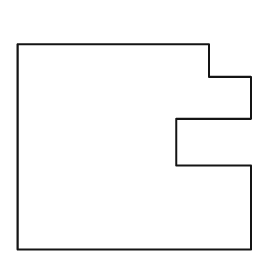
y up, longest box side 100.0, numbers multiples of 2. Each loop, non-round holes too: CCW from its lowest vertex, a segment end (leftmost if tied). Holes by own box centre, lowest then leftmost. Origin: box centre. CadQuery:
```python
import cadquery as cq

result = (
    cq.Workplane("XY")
    .moveTo(-50.0, -44.0)
    .lineTo(50.0, -44.0)
    .lineTo(50.0, -8.0)
    .lineTo(18.0, -8.0)
    .lineTo(18.0, 12.0)
    .lineTo(50.0, 12.0)
    .lineTo(50.0, 30.0)
    .lineTo(32.0, 30.0)
    .lineTo(32.0, 44.0)
    .lineTo(-50.0, 44.0)
    .close()
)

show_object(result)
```